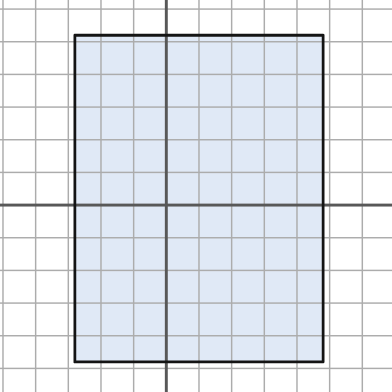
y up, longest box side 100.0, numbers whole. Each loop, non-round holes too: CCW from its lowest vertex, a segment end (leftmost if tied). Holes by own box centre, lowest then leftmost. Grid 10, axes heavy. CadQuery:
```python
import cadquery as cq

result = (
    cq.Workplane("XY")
    .moveTo(-28.0, -48.0)
    .lineTo(48.0, -48.0)
    .lineTo(48.0, 52.0)
    .lineTo(-28.0, 52.0)
    .close()
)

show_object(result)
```